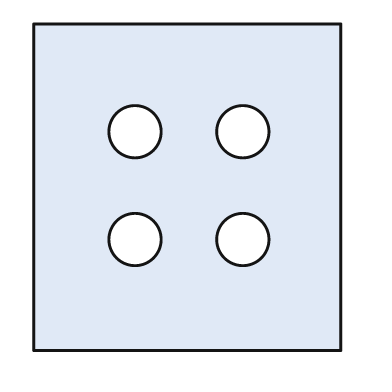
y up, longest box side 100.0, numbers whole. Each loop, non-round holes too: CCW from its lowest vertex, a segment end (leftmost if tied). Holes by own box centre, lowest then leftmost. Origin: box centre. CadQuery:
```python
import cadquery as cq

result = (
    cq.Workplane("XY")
    .moveTo(-47.0, -50.0)
    .lineTo(47.0, -50.0)
    .lineTo(47.0, 50.0)
    .lineTo(-47.0, 50.0)
    .close()
    .moveTo(-16.0, -16.0)
    .circle(8.0)
    .moveTo(17.0, -16.0)
    .circle(8.0)
    .moveTo(-16.0, 17.0)
    .circle(8.0)
    .moveTo(17.0, 17.0)
    .circle(8.0)
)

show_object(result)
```